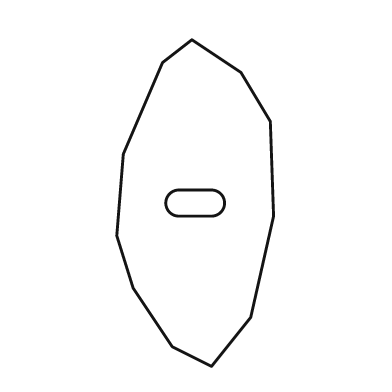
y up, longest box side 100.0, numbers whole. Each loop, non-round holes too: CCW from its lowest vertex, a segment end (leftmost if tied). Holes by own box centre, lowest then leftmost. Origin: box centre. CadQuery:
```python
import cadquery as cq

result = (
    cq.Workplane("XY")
    .moveTo(5.0, -50.0)
    .lineTo(17.0, -35.0)
    .lineTo(24.0, -4.0)
    .lineTo(23.0, 25.0)
    .lineTo(14.0, 40.0)
    .lineTo(-1.0, 50.0)
    .lineTo(-10.0, 43.0)
    .lineTo(-22.0, 15.0)
    .lineTo(-24.0, -10.0)
    .lineTo(-19.0, -26.0)
    .lineTo(-7.0, -44.0)
    .close()
    .moveTo(-5.0, -4.0)
    .lineTo(5.0, -4.0)
    .threePointArc((9.0, 0.0), (5.0, 4.0))
    .lineTo(-5.0, 4.0)
    .threePointArc((-9.0, 0.0), (-5.0, -4.0))
    .close()
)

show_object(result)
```